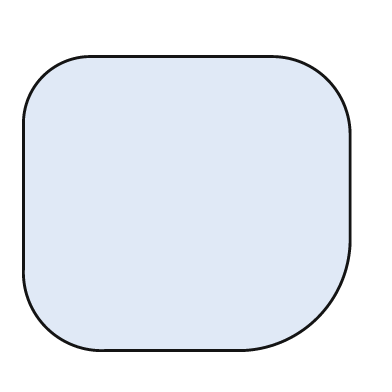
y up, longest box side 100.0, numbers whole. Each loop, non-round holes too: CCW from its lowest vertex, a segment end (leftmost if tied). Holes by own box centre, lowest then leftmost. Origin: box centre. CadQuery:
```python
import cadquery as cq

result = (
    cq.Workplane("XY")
    .moveTo(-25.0, -45.0)
    .lineTo(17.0, -45.0)
    .threePointArc((40.0, -35.0), (50.0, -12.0))
    .lineTo(50.0, 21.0)
    .threePointArc((43.0, 38.0), (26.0, 45.0))
    .lineTo(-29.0, 45.0)
    .threePointArc((-44.0, 39.0), (-50.0, 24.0))
    .lineTo(-50.0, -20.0)
    .threePointArc((-43.0, -38.0), (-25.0, -45.0))
    .close()
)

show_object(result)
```